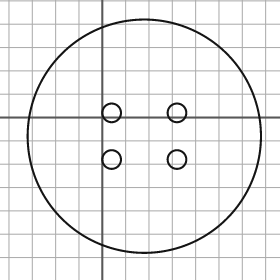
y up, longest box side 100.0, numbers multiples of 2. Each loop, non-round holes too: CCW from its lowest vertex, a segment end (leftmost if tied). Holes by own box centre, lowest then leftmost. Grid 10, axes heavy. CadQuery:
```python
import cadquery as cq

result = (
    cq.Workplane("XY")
    .moveTo(18.0, -8.0)
    .circle(50.0)
    .moveTo(4.0, -18.0)
    .circle(4.0)
    .moveTo(32.0, -18.0)
    .circle(4.0)
    .moveTo(4.0, 2.0)
    .circle(4.0)
    .moveTo(32.0, 2.0)
    .circle(4.0)
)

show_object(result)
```